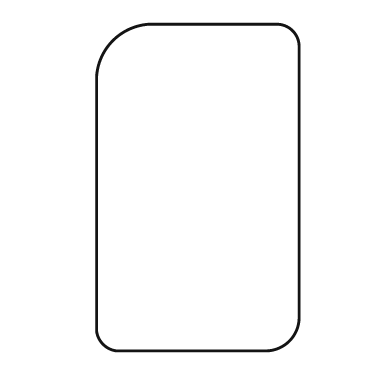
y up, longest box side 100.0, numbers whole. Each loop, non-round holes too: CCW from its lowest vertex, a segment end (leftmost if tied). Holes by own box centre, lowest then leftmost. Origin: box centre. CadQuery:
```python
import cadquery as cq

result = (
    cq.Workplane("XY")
    .moveTo(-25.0, -50.0)
    .lineTo(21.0, -50.0)
    .threePointArc((28.0, -47.0), (31.0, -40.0))
    .lineTo(31.0, 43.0)
    .threePointArc((29.0, 48.0), (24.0, 50.0))
    .lineTo(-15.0, 50.0)
    .threePointArc((-26.0, 45.0), (-31.0, 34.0))
    .lineTo(-31.0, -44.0)
    .threePointArc((-29.0, -48.0), (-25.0, -50.0))
    .close()
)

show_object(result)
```